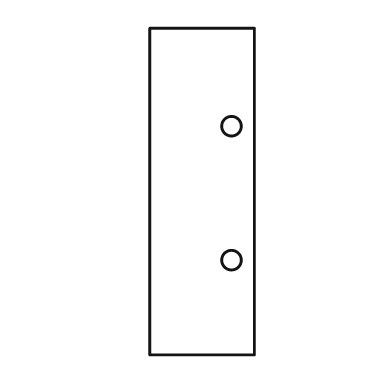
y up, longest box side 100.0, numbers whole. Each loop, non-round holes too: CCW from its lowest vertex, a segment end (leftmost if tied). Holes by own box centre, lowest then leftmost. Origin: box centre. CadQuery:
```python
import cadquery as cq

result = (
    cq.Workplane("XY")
    .moveTo(-16.0, -50.0)
    .lineTo(16.0, -50.0)
    .lineTo(16.0, 50.0)
    .lineTo(-16.0, 50.0)
    .close()
    .moveTo(9.0, -21.0)
    .circle(3.0)
    .moveTo(9.0, 20.0)
    .circle(3.0)
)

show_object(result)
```